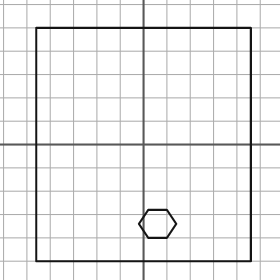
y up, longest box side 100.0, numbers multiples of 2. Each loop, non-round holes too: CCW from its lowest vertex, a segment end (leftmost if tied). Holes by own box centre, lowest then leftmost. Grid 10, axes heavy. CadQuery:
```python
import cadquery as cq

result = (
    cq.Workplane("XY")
    .moveTo(-46.0, -50.0)
    .lineTo(46.0, -50.0)
    .lineTo(46.0, 50.0)
    .lineTo(-46.0, 50.0)
    .close()
    .moveTo(2.0, -40.0)
    .lineTo(10.0, -40.0)
    .lineTo(14.0, -34.0)
    .lineTo(10.0, -28.0)
    .lineTo(2.0, -28.0)
    .lineTo(-2.0, -34.0)
    .close()
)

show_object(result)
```